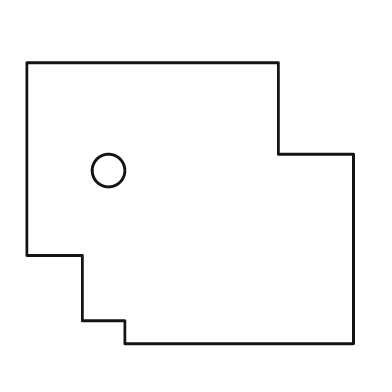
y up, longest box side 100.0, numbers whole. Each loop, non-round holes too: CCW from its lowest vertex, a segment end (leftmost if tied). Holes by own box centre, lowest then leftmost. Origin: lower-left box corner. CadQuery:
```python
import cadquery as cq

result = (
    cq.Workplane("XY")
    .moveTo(30.0, 0.0)
    .lineTo(100.0, 0.0)
    .lineTo(100.0, 58.0)
    .lineTo(77.0, 58.0)
    .lineTo(77.0, 86.0)
    .lineTo(0.0, 86.0)
    .lineTo(0.0, 27.0)
    .lineTo(17.0, 27.0)
    .lineTo(17.0, 7.0)
    .lineTo(30.0, 7.0)
    .close()
    .moveTo(25.0, 53.0)
    .circle(5.0)
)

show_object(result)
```